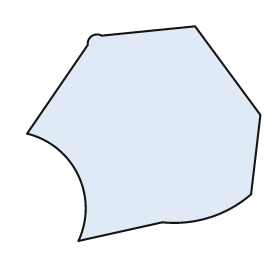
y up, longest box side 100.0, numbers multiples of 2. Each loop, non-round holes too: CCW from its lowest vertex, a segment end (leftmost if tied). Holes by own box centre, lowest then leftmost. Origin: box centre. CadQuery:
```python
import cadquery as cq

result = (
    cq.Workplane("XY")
    .moveTo(-28.0, -46.0)
    .lineTo(8.0, -38.0)
    .threePointArc((28.0, -36.0), (46.0, -26.0))
    .lineTo(50.0, 8.0)
    .lineTo(22.0, 46.0)
    .lineTo(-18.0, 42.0)
    .threePointArc((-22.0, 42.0), (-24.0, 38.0))
    .lineTo(-50.0, 0.0)
    .threePointArc((-28.0, -18.0), (-28.0, -46.0))
    .close()
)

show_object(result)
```